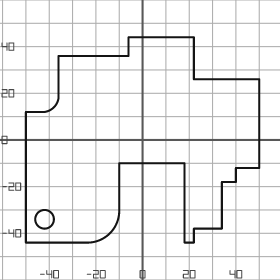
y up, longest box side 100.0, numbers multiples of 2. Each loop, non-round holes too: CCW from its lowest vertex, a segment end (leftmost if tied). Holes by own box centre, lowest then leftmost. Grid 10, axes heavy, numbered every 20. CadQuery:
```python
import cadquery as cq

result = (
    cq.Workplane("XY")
    .moveTo(-50.0, -44.0)
    .lineTo(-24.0, -44.0)
    .threePointArc((-14.0, -40.0), (-10.0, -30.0))
    .lineTo(-10.0, -10.0)
    .lineTo(18.0, -10.0)
    .lineTo(18.0, -44.0)
    .lineTo(22.0, -44.0)
    .lineTo(22.0, -38.0)
    .lineTo(34.0, -38.0)
    .lineTo(34.0, -18.0)
    .lineTo(40.0, -18.0)
    .lineTo(40.0, -12.0)
    .lineTo(50.0, -12.0)
    .lineTo(50.0, 26.0)
    .lineTo(22.0, 26.0)
    .lineTo(22.0, 44.0)
    .lineTo(-6.0, 44.0)
    .lineTo(-6.0, 36.0)
    .lineTo(-36.0, 36.0)
    .lineTo(-36.0, 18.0)
    .threePointArc((-38.0, 14.0), (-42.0, 12.0))
    .lineTo(-50.0, 12.0)
    .close()
    .moveTo(-42.0, -34.0)
    .circle(4.0)
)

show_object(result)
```